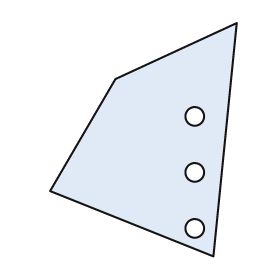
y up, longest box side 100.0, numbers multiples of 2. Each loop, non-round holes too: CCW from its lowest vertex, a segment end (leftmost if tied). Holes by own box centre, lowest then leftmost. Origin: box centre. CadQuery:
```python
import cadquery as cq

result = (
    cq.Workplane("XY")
    .moveTo(30.0, -50.0)
    .lineTo(40.0, 50.0)
    .lineTo(-12.0, 26.0)
    .lineTo(-40.0, -22.0)
    .close()
    .moveTo(22.0, -38.0)
    .circle(4.0)
    .moveTo(22.0, -14.0)
    .circle(4.0)
    .moveTo(22.0, 10.0)
    .circle(4.0)
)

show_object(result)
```